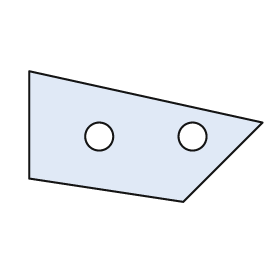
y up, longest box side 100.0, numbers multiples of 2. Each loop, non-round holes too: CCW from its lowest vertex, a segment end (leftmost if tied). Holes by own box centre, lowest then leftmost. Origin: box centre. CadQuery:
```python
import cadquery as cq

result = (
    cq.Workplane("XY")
    .moveTo(16.0, -28.0)
    .lineTo(50.0, 6.0)
    .lineTo(-50.0, 28.0)
    .lineTo(-50.0, -18.0)
    .close()
    .moveTo(-20.0, 0.0)
    .circle(6.0)
    .moveTo(20.0, 0.0)
    .circle(6.0)
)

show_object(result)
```